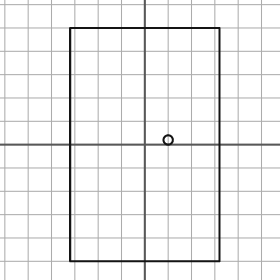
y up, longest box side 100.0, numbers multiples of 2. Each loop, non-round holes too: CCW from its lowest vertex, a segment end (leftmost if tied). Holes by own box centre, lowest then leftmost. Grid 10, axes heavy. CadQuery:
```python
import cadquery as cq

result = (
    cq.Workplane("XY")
    .moveTo(-32.0, -50.0)
    .lineTo(32.0, -50.0)
    .lineTo(32.0, 50.0)
    .lineTo(-32.0, 50.0)
    .close()
    .moveTo(10.0, 2.0)
    .circle(2.0)
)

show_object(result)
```